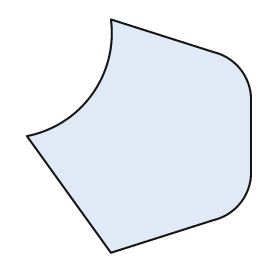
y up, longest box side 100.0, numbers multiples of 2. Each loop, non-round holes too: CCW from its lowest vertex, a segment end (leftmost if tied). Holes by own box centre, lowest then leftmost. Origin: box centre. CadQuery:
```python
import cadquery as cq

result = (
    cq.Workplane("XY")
    .moveTo(-12.0, -50.0)
    .lineTo(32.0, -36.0)
    .threePointArc((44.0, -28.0), (48.0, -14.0))
    .lineTo(48.0, 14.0)
    .threePointArc((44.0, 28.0), (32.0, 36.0))
    .lineTo(-12.0, 50.0)
    .threePointArc((-20.0, 18.0), (-48.0, 0.0))
    .close()
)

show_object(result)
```